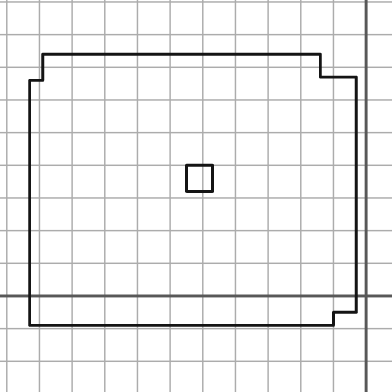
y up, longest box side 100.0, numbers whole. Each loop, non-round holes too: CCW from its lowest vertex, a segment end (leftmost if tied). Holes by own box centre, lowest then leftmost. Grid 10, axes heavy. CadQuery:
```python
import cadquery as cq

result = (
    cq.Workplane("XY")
    .moveTo(-103.0, -9.0)
    .lineTo(-10.0, -9.0)
    .lineTo(-10.0, -5.0)
    .lineTo(-3.0, -5.0)
    .lineTo(-3.0, 67.0)
    .lineTo(-14.0, 67.0)
    .lineTo(-14.0, 74.0)
    .lineTo(-99.0, 74.0)
    .lineTo(-99.0, 66.0)
    .lineTo(-103.0, 66.0)
    .close()
    .moveTo(-55.0, 32.0)
    .lineTo(-47.0, 32.0)
    .lineTo(-47.0, 40.0)
    .lineTo(-55.0, 40.0)
    .close()
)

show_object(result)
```